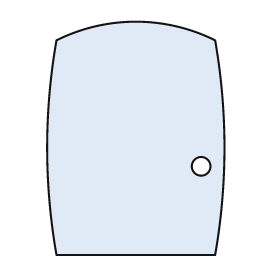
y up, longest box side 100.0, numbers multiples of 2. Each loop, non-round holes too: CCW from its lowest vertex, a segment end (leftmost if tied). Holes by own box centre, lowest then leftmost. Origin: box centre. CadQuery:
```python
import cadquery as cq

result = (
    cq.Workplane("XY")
    .moveTo(-34.0, -50.0)
    .lineTo(34.0, -50.0)
    .threePointArc((38.0, -4.0), (34.0, 42.0))
    .threePointArc((0.0, 50.0), (-34.0, 42.0))
    .threePointArc((-38.0, -4.0), (-34.0, -50.0))
    .close()
    .moveTo(28.0, -12.0)
    .circle(4.0)
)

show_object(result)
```